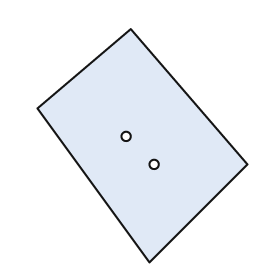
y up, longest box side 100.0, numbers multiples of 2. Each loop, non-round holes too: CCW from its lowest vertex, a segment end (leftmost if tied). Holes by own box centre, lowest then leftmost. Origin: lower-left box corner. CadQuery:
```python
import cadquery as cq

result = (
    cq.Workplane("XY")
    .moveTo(48.0, 0.0)
    .lineTo(90.0, 42.0)
    .lineTo(40.0, 100.0)
    .lineTo(0.0, 66.0)
    .close()
    .moveTo(50.0, 42.0)
    .circle(2.0)
    .moveTo(38.0, 54.0)
    .circle(2.0)
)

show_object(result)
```